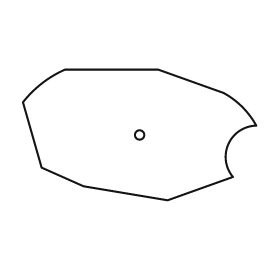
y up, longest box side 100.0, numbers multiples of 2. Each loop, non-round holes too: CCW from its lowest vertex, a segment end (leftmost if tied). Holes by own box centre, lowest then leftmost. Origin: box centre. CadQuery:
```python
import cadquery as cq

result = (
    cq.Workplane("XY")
    .moveTo(12.0, -28.0)
    .lineTo(40.0, -18.0)
    .threePointArc((38.0, -4.0), (50.0, 4.0))
    .threePointArc((44.0, 12.0), (36.0, 18.0))
    .lineTo(8.0, 28.0)
    .lineTo(-32.0, 28.0)
    .threePointArc((-42.0, 22.0), (-50.0, 14.0))
    .lineTo(-42.0, -14.0)
    .lineTo(-24.0, -22.0)
    .close()
    .moveTo(0.0, 0.0)
    .circle(2.0)
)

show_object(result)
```